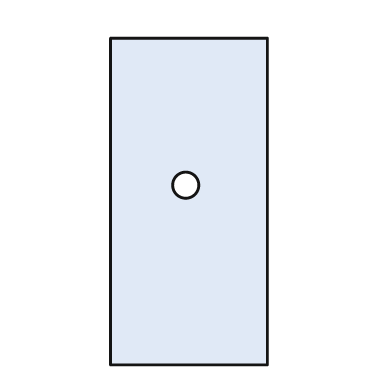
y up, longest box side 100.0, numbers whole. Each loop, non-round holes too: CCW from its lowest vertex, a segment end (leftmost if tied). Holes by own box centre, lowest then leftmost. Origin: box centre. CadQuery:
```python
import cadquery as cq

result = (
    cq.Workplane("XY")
    .moveTo(-24.0, -50.0)
    .lineTo(24.0, -50.0)
    .lineTo(24.0, 50.0)
    .lineTo(-24.0, 50.0)
    .close()
    .moveTo(-1.0, 5.0)
    .circle(4.0)
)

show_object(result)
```